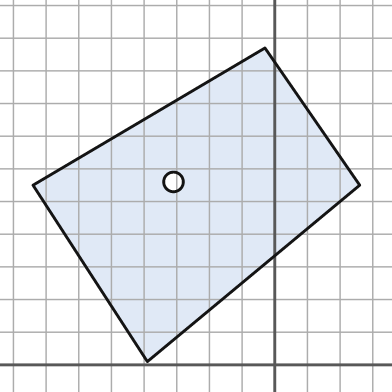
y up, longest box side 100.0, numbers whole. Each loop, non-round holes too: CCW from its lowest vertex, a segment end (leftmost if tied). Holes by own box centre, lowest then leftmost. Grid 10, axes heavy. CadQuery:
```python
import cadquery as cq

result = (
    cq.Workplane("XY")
    .moveTo(-39.0, 1.0)
    .lineTo(26.0, 55.0)
    .lineTo(-3.0, 97.0)
    .lineTo(-74.0, 55.0)
    .close()
    .moveTo(-31.0, 56.0)
    .circle(3.0)
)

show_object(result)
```